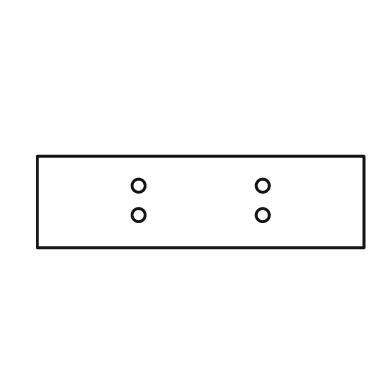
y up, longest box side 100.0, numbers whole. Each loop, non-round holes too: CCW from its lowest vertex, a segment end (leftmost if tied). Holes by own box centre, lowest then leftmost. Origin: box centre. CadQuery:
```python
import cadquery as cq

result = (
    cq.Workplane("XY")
    .moveTo(-50.0, -14.0)
    .lineTo(50.0, -14.0)
    .lineTo(50.0, 14.0)
    .lineTo(-50.0, 14.0)
    .close()
    .moveTo(-19.0, -4.0)
    .circle(2.0)
    .moveTo(19.0, -4.0)
    .circle(2.0)
    .moveTo(-19.0, 5.0)
    .circle(2.0)
    .moveTo(19.0, 5.0)
    .circle(2.0)
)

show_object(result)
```